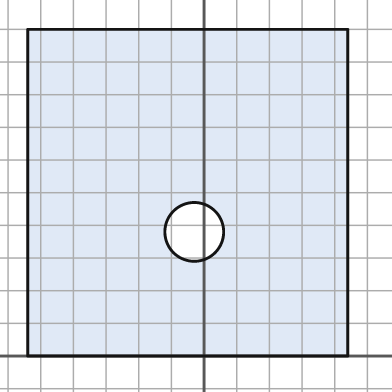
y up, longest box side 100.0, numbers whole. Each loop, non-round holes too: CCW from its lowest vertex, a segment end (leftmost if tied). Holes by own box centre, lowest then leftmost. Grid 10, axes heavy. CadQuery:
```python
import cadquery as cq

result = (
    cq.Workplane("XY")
    .moveTo(-54.0, 0.0)
    .lineTo(44.0, 0.0)
    .lineTo(44.0, 100.0)
    .lineTo(-54.0, 100.0)
    .close()
    .moveTo(-3.0, 38.0)
    .circle(9.0)
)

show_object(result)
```